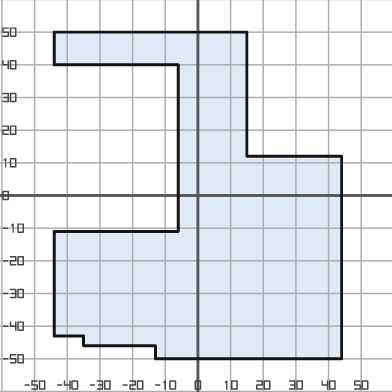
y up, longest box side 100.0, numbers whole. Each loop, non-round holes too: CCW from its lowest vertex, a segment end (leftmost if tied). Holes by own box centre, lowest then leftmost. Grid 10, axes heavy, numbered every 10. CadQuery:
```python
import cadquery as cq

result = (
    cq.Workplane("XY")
    .moveTo(-13.0, -50.0)
    .lineTo(44.0, -50.0)
    .lineTo(44.0, 12.0)
    .lineTo(15.0, 12.0)
    .lineTo(15.0, 50.0)
    .lineTo(-44.0, 50.0)
    .lineTo(-44.0, 40.0)
    .lineTo(-6.0, 40.0)
    .lineTo(-6.0, -11.0)
    .lineTo(-44.0, -11.0)
    .lineTo(-44.0, -43.0)
    .lineTo(-35.0, -43.0)
    .lineTo(-35.0, -46.0)
    .lineTo(-13.0, -46.0)
    .close()
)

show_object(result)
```